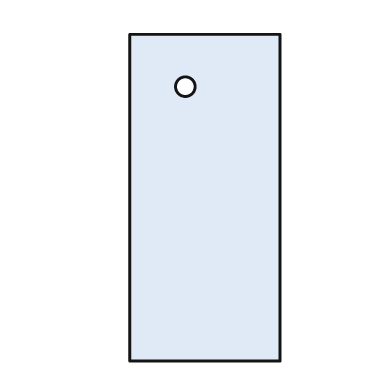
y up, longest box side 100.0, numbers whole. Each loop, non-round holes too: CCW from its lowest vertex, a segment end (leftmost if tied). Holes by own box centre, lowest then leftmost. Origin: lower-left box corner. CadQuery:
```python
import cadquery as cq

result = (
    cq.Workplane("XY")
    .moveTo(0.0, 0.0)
    .lineTo(46.0, 0.0)
    .lineTo(46.0, 100.0)
    .lineTo(0.0, 100.0)
    .close()
    .moveTo(17.0, 84.0)
    .circle(3.0)
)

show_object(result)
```